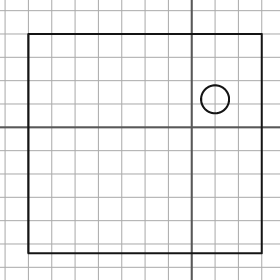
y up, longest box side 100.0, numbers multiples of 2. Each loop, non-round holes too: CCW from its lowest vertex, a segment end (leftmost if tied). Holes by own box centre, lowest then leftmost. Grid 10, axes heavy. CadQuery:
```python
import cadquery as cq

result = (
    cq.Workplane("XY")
    .moveTo(-70.0, -54.0)
    .lineTo(30.0, -54.0)
    .lineTo(30.0, 40.0)
    .lineTo(-70.0, 40.0)
    .close()
    .moveTo(10.0, 12.0)
    .circle(6.0)
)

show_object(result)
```